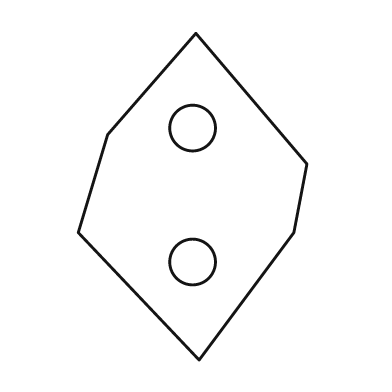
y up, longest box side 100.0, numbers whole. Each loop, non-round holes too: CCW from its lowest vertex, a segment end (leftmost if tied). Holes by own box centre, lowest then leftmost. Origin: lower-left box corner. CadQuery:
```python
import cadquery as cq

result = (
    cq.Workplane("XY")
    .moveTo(37.0, 0.0)
    .lineTo(66.0, 39.0)
    .lineTo(70.0, 60.0)
    .lineTo(36.0, 100.0)
    .lineTo(9.0, 69.0)
    .lineTo(0.0, 39.0)
    .close()
    .moveTo(35.0, 30.0)
    .circle(7.0)
    .moveTo(35.0, 71.0)
    .circle(7.0)
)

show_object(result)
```